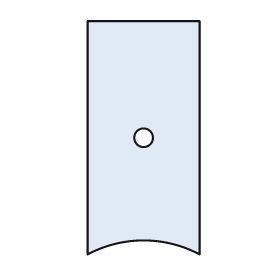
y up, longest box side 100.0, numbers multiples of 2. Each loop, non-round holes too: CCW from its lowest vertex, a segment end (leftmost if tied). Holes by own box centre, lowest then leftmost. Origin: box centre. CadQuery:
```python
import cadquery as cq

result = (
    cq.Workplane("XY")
    .moveTo(-24.0, -50.0)
    .threePointArc((0.0, -44.0), (24.0, -50.0))
    .lineTo(24.0, 50.0)
    .lineTo(-24.0, 50.0)
    .close()
    .moveTo(0.0, 0.0)
    .circle(4.0)
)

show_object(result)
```